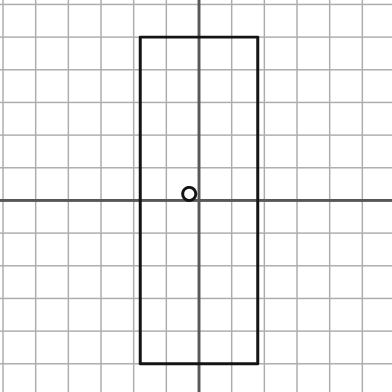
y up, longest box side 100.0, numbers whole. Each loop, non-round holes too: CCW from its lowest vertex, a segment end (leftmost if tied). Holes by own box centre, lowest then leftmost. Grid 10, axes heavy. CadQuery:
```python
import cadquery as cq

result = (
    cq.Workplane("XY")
    .moveTo(-18.0, -50.0)
    .lineTo(18.0, -50.0)
    .lineTo(18.0, 50.0)
    .lineTo(-18.0, 50.0)
    .close()
    .moveTo(-3.0, 2.0)
    .circle(2.0)
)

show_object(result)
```